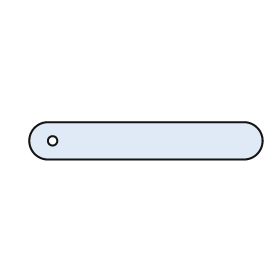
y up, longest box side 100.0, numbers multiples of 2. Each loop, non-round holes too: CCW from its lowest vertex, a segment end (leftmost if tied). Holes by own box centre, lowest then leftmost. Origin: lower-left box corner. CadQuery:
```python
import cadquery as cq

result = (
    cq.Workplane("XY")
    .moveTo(8.0, 0.0)
    .lineTo(92.0, 0.0)
    .threePointArc((100.0, 8.0), (92.0, 16.0))
    .lineTo(8.0, 16.0)
    .threePointArc((0.0, 8.0), (8.0, 0.0))
    .close()
    .moveTo(10.0, 8.0)
    .circle(2.0)
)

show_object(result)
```